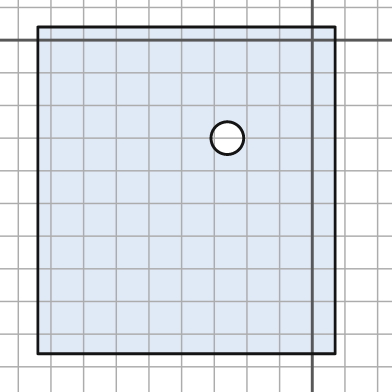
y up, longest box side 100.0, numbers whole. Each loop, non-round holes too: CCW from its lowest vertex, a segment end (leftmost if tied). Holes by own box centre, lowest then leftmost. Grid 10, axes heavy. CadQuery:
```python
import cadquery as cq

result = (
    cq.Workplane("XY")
    .moveTo(-84.0, -96.0)
    .lineTo(7.0, -96.0)
    .lineTo(7.0, 4.0)
    .lineTo(-84.0, 4.0)
    .close()
    .moveTo(-26.0, -30.0)
    .circle(5.0)
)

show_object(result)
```